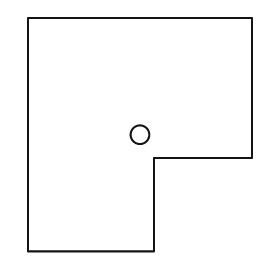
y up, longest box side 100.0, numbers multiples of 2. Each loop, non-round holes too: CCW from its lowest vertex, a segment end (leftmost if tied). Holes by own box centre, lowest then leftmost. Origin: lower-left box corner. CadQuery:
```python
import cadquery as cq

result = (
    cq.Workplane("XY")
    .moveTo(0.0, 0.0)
    .lineTo(54.0, 0.0)
    .lineTo(54.0, 40.0)
    .lineTo(96.0, 40.0)
    .lineTo(96.0, 100.0)
    .lineTo(0.0, 100.0)
    .close()
    .moveTo(48.0, 50.0)
    .circle(4.0)
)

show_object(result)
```